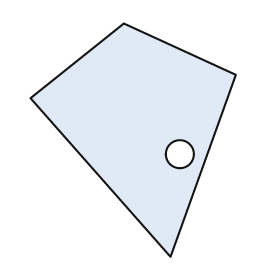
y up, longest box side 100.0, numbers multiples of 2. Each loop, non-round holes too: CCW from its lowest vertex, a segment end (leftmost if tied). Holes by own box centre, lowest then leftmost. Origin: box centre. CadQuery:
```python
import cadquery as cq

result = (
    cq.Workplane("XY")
    .moveTo(16.0, -50.0)
    .lineTo(44.0, 28.0)
    .lineTo(-4.0, 50.0)
    .lineTo(-44.0, 18.0)
    .close()
    .moveTo(20.0, -6.0)
    .circle(6.0)
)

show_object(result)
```